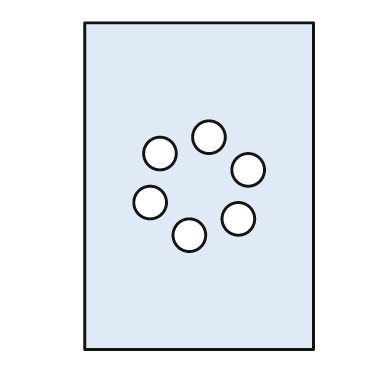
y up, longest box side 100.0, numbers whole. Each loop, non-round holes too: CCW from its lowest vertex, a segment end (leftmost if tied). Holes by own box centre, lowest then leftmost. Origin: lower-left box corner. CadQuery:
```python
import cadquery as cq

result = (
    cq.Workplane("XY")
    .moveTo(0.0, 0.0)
    .lineTo(70.0, 0.0)
    .lineTo(70.0, 100.0)
    .lineTo(0.0, 100.0)
    .close()
    .moveTo(32.0, 35.0)
    .circle(5.0)
    .moveTo(47.0, 40.0)
    .circle(5.0)
    .moveTo(20.0, 45.0)
    .circle(5.0)
    .moveTo(50.0, 55.0)
    .circle(5.0)
    .moveTo(23.0, 60.0)
    .circle(5.0)
    .moveTo(38.0, 65.0)
    .circle(5.0)
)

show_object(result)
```